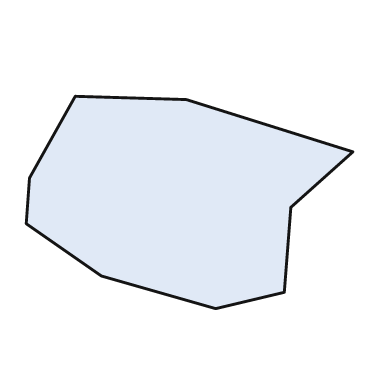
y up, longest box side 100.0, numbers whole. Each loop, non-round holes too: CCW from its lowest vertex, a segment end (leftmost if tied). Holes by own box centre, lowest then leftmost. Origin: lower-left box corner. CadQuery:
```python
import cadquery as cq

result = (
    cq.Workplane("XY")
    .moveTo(58.0, 0.0)
    .lineTo(79.0, 5.0)
    .lineTo(81.0, 31.0)
    .lineTo(100.0, 48.0)
    .lineTo(49.0, 64.0)
    .lineTo(15.0, 65.0)
    .lineTo(1.0, 40.0)
    .lineTo(0.0, 26.0)
    .lineTo(23.0, 10.0)
    .close()
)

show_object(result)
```